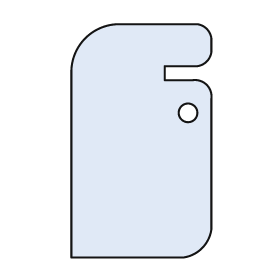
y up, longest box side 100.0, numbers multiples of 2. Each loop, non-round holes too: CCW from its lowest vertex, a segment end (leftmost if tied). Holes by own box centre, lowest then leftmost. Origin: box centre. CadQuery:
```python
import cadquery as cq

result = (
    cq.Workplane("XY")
    .moveTo(-30.0, -50.0)
    .lineTo(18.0, -50.0)
    .threePointArc((26.0, -46.0), (30.0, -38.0))
    .lineTo(30.0, 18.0)
    .threePointArc((28.0, 24.0), (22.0, 26.0))
    .lineTo(10.0, 26.0)
    .lineTo(10.0, 32.0)
    .lineTo(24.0, 32.0)
    .threePointArc((28.0, 34.0), (30.0, 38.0))
    .lineTo(30.0, 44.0)
    .threePointArc((28.0, 48.0), (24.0, 50.0))
    .lineTo(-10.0, 50.0)
    .threePointArc((-24.0, 44.0), (-30.0, 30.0))
    .close()
    .moveTo(20.0, 12.0)
    .circle(4.0)
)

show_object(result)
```